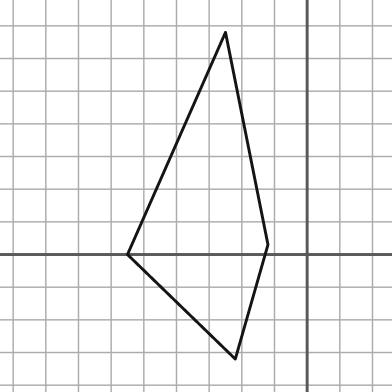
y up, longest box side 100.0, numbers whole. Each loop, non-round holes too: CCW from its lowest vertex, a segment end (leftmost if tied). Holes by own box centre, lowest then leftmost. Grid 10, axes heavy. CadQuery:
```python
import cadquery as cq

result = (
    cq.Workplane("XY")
    .moveTo(-22.0, -32.0)
    .lineTo(-12.0, 3.0)
    .lineTo(-25.0, 68.0)
    .lineTo(-55.0, 0.0)
    .close()
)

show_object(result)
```